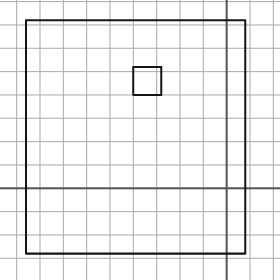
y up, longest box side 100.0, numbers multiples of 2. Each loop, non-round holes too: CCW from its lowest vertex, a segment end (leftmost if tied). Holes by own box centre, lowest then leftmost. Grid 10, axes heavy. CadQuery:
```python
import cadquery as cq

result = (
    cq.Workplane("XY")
    .moveTo(-86.0, -28.0)
    .lineTo(8.0, -28.0)
    .lineTo(8.0, 72.0)
    .lineTo(-86.0, 72.0)
    .close()
    .moveTo(-40.0, 40.0)
    .lineTo(-28.0, 40.0)
    .lineTo(-28.0, 52.0)
    .lineTo(-40.0, 52.0)
    .close()
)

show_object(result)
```